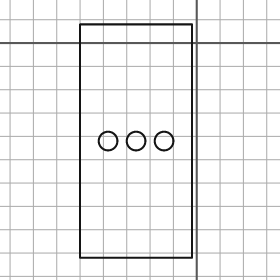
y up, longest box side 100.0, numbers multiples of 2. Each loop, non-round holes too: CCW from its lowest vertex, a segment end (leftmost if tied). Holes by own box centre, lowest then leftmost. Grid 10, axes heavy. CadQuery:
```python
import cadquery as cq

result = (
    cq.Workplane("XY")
    .moveTo(-50.0, -92.0)
    .lineTo(-2.0, -92.0)
    .lineTo(-2.0, 8.0)
    .lineTo(-50.0, 8.0)
    .close()
    .moveTo(-38.0, -42.0)
    .circle(4.0)
    .moveTo(-26.0, -42.0)
    .circle(4.0)
    .moveTo(-14.0, -42.0)
    .circle(4.0)
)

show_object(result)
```